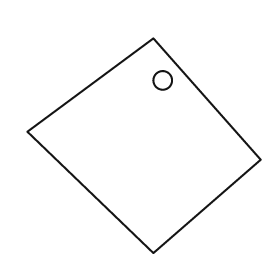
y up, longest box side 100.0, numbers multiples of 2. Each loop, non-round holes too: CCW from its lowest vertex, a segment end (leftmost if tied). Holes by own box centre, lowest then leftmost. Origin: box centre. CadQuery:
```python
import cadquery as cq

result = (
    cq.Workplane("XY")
    .moveTo(4.0, -46.0)
    .lineTo(50.0, -6.0)
    .lineTo(4.0, 46.0)
    .lineTo(-50.0, 6.0)
    .close()
    .moveTo(8.0, 28.0)
    .circle(4.0)
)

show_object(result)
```